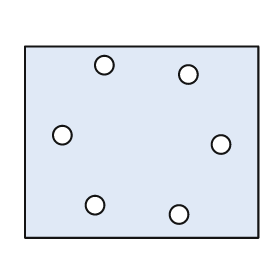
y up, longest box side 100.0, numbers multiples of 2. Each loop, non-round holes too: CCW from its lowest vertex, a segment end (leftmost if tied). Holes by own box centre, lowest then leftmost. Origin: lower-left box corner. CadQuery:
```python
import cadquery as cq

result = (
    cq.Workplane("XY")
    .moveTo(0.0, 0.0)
    .lineTo(100.0, 0.0)
    .lineTo(100.0, 82.0)
    .lineTo(0.0, 82.0)
    .close()
    .moveTo(66.0, 10.0)
    .circle(4.0)
    .moveTo(30.0, 14.0)
    .circle(4.0)
    .moveTo(84.0, 40.0)
    .circle(4.0)
    .moveTo(16.0, 44.0)
    .circle(4.0)
    .moveTo(70.0, 70.0)
    .circle(4.0)
    .moveTo(34.0, 74.0)
    .circle(4.0)
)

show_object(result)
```